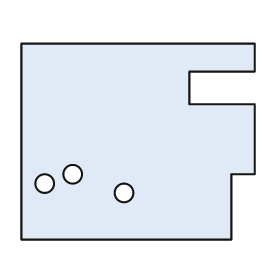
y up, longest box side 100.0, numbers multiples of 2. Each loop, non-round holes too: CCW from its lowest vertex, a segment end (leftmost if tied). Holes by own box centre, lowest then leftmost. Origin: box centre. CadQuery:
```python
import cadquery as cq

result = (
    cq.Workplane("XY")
    .moveTo(-50.0, -42.0)
    .lineTo(40.0, -42.0)
    .lineTo(40.0, -14.0)
    .lineTo(50.0, -14.0)
    .lineTo(50.0, 16.0)
    .lineTo(22.0, 16.0)
    .lineTo(22.0, 30.0)
    .lineTo(50.0, 30.0)
    .lineTo(50.0, 42.0)
    .lineTo(-50.0, 42.0)
    .close()
    .moveTo(-6.0, -22.0)
    .circle(4.0)
    .moveTo(-40.0, -18.0)
    .circle(4.0)
    .moveTo(-28.0, -14.0)
    .circle(4.0)
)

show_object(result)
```